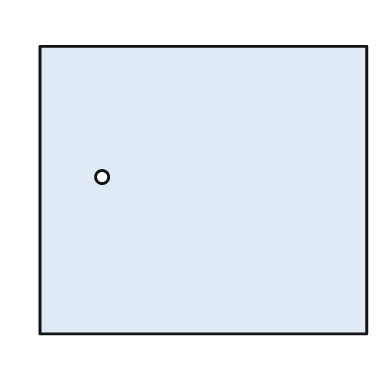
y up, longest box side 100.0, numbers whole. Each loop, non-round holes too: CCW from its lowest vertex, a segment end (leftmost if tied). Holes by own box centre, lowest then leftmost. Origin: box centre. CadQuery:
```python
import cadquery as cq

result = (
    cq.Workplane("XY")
    .moveTo(-50.0, -44.0)
    .lineTo(50.0, -44.0)
    .lineTo(50.0, 44.0)
    .lineTo(-50.0, 44.0)
    .close()
    .moveTo(-31.0, 4.0)
    .circle(2.0)
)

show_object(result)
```